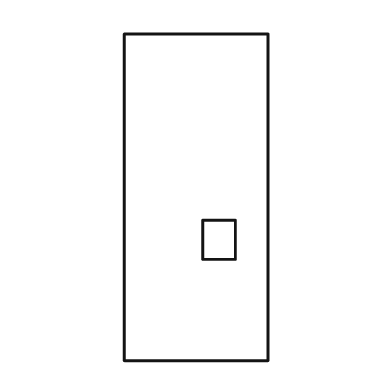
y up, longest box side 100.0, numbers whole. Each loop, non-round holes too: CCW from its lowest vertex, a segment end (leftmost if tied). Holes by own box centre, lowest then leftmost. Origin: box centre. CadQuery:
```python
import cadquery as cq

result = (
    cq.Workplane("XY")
    .moveTo(-22.0, -50.0)
    .lineTo(22.0, -50.0)
    .lineTo(22.0, 50.0)
    .lineTo(-22.0, 50.0)
    .close()
    .moveTo(2.0, -19.0)
    .lineTo(12.0, -19.0)
    .lineTo(12.0, -7.0)
    .lineTo(2.0, -7.0)
    .close()
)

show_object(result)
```